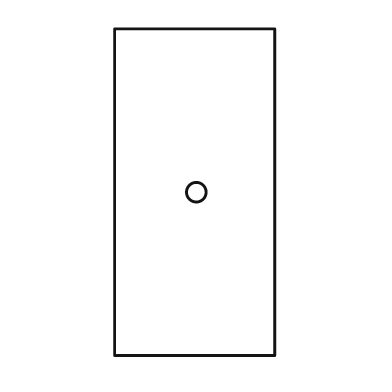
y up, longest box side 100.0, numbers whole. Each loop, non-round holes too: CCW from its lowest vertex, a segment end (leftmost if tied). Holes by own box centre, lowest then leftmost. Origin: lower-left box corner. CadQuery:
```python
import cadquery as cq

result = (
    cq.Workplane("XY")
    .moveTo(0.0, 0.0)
    .lineTo(49.0, 0.0)
    .lineTo(49.0, 100.0)
    .lineTo(0.0, 100.0)
    .close()
    .moveTo(25.0, 50.0)
    .circle(3.0)
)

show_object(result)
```